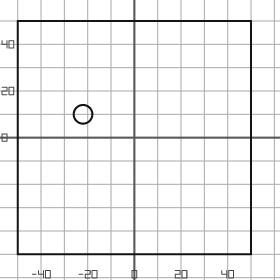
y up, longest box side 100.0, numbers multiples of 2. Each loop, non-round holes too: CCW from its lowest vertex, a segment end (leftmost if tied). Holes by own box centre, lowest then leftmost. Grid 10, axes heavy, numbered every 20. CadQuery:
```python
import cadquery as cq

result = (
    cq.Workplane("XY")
    .moveTo(-50.0, -50.0)
    .lineTo(50.0, -50.0)
    .lineTo(50.0, 50.0)
    .lineTo(-50.0, 50.0)
    .close()
    .moveTo(-22.0, 10.0)
    .circle(4.0)
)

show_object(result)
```